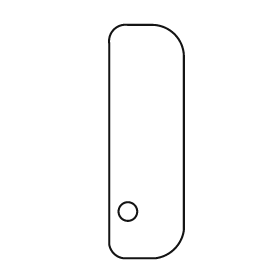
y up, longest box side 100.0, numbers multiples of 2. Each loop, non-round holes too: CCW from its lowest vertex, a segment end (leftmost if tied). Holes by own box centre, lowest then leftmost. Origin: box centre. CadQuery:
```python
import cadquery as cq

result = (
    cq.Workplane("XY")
    .moveTo(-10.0, -50.0)
    .lineTo(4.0, -50.0)
    .threePointArc((12.0, -46.0), (16.0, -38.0))
    .lineTo(16.0, 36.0)
    .threePointArc((12.0, 46.0), (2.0, 50.0))
    .lineTo(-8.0, 50.0)
    .threePointArc((-14.0, 48.0), (-16.0, 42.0))
    .lineTo(-16.0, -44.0)
    .threePointArc((-14.0, -48.0), (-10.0, -50.0))
    .close()
    .moveTo(-8.0, -30.0)
    .circle(4.0)
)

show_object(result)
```